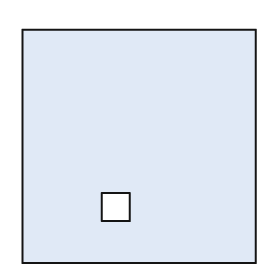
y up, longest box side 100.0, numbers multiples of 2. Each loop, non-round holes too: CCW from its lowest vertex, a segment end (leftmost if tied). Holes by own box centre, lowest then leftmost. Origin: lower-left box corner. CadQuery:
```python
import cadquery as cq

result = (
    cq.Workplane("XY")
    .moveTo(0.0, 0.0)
    .lineTo(100.0, 0.0)
    .lineTo(100.0, 100.0)
    .lineTo(0.0, 100.0)
    .close()
    .moveTo(34.0, 18.0)
    .lineTo(46.0, 18.0)
    .lineTo(46.0, 30.0)
    .lineTo(34.0, 30.0)
    .close()
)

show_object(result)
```